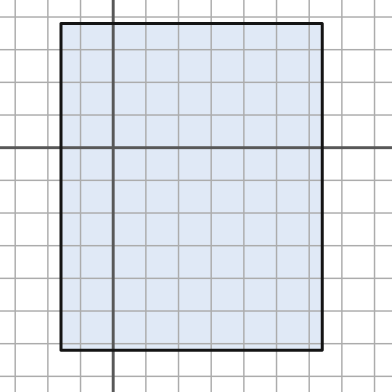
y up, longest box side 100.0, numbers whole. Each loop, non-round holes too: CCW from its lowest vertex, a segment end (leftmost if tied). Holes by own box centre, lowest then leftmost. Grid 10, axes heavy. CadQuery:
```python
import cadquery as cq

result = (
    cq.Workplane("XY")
    .moveTo(-16.0, -62.0)
    .lineTo(64.0, -62.0)
    .lineTo(64.0, 38.0)
    .lineTo(-16.0, 38.0)
    .close()
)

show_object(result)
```